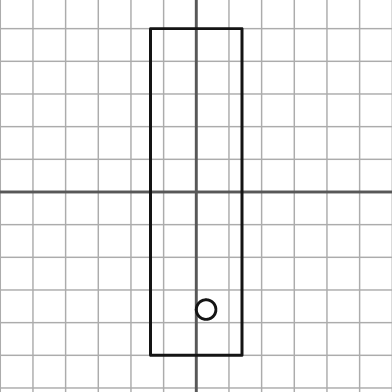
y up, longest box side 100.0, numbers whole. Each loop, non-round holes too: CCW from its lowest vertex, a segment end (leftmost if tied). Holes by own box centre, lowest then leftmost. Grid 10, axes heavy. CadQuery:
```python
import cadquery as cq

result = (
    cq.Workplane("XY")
    .moveTo(-14.0, -50.0)
    .lineTo(14.0, -50.0)
    .lineTo(14.0, 50.0)
    .lineTo(-14.0, 50.0)
    .close()
    .moveTo(3.0, -36.0)
    .circle(3.0)
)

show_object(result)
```